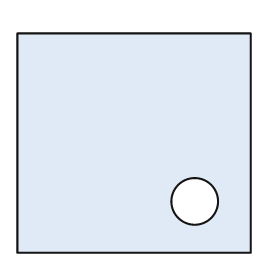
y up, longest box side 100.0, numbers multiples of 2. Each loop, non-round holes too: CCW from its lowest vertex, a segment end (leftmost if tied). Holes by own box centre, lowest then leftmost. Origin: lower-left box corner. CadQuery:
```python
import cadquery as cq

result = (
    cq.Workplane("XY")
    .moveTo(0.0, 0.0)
    .lineTo(100.0, 0.0)
    .lineTo(100.0, 94.0)
    .lineTo(0.0, 94.0)
    .close()
    .moveTo(76.0, 22.0)
    .circle(10.0)
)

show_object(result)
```